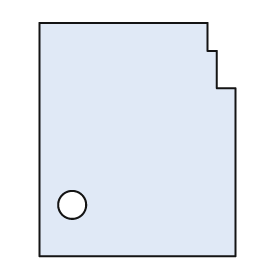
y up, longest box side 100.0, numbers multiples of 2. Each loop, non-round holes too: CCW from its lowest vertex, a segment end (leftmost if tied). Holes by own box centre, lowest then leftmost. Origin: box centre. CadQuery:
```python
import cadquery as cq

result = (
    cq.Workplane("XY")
    .moveTo(-42.0, -50.0)
    .lineTo(42.0, -50.0)
    .lineTo(42.0, 22.0)
    .lineTo(34.0, 22.0)
    .lineTo(34.0, 38.0)
    .lineTo(30.0, 38.0)
    .lineTo(30.0, 50.0)
    .lineTo(-42.0, 50.0)
    .close()
    .moveTo(-28.0, -28.0)
    .circle(6.0)
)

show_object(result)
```